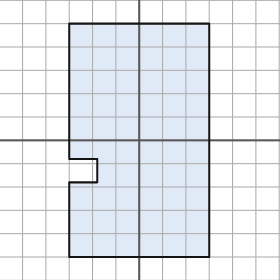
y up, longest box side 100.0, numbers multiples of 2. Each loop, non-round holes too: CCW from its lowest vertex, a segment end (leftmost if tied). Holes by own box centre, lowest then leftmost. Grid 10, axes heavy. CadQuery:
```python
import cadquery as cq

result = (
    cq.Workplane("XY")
    .moveTo(-30.0, -50.0)
    .lineTo(30.0, -50.0)
    .lineTo(30.0, 50.0)
    .lineTo(-30.0, 50.0)
    .lineTo(-30.0, -8.0)
    .lineTo(-18.0, -8.0)
    .lineTo(-18.0, -18.0)
    .lineTo(-30.0, -18.0)
    .close()
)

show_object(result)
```